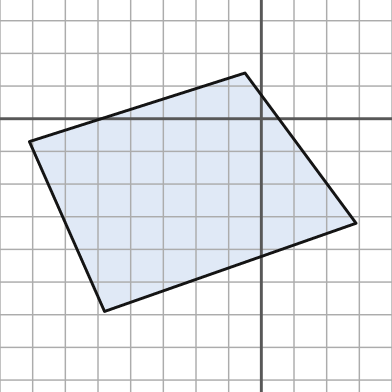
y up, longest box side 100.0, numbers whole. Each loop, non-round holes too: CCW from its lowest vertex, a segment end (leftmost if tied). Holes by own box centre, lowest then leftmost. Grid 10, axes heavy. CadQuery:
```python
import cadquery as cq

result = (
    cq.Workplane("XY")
    .moveTo(-48.0, -59.0)
    .lineTo(29.0, -32.0)
    .lineTo(-5.0, 14.0)
    .lineTo(-71.0, -7.0)
    .close()
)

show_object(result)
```